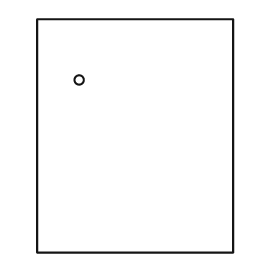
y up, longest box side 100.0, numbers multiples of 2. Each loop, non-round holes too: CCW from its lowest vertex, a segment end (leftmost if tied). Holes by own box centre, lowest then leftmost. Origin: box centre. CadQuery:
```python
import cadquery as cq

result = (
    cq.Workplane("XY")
    .moveTo(-42.0, -50.0)
    .lineTo(42.0, -50.0)
    .lineTo(42.0, 50.0)
    .lineTo(-42.0, 50.0)
    .close()
    .moveTo(-24.0, 24.0)
    .circle(2.0)
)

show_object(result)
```